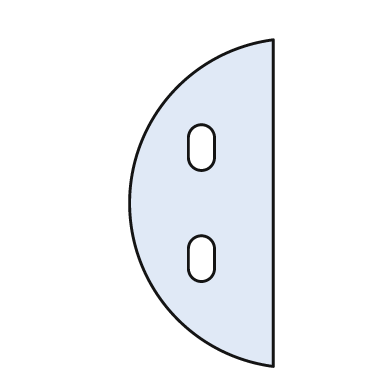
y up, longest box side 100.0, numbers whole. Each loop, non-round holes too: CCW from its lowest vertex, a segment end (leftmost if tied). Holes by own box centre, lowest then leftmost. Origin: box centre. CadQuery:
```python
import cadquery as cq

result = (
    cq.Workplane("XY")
    .moveTo(22.0, -50.0)
    .lineTo(22.0, 50.0)
    .threePointArc((-22.0, 0.0), (22.0, -50.0))
    .close()
    .moveTo(-4.0, -20.0)
    .threePointArc((0.0, -24.0), (4.0, -20.0))
    .lineTo(4.0, -14.0)
    .threePointArc((0.0, -10.0), (-4.0, -14.0))
    .close()
    .moveTo(-4.0, 14.0)
    .threePointArc((0.0, 10.0), (4.0, 14.0))
    .lineTo(4.0, 20.0)
    .threePointArc((0.0, 24.0), (-4.0, 20.0))
    .close()
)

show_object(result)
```